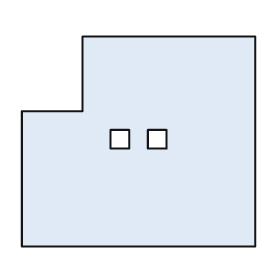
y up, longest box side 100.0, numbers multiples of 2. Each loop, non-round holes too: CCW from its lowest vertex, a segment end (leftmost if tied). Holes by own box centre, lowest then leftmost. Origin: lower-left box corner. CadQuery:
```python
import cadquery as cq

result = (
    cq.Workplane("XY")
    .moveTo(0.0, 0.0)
    .lineTo(100.0, 0.0)
    .lineTo(100.0, 90.0)
    .lineTo(26.0, 90.0)
    .lineTo(26.0, 58.0)
    .lineTo(0.0, 58.0)
    .close()
    .moveTo(38.0, 42.0)
    .lineTo(46.0, 42.0)
    .lineTo(46.0, 50.0)
    .lineTo(38.0, 50.0)
    .close()
    .moveTo(54.0, 42.0)
    .lineTo(62.0, 42.0)
    .lineTo(62.0, 50.0)
    .lineTo(54.0, 50.0)
    .close()
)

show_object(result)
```